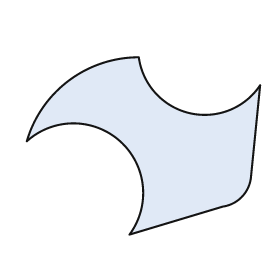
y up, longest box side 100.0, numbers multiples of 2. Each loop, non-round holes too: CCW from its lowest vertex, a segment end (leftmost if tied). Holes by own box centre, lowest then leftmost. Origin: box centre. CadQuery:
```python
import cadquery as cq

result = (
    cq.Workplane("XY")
    .moveTo(-6.0, -38.0)
    .lineTo(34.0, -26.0)
    .threePointArc((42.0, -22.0), (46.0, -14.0))
    .lineTo(50.0, 26.0)
    .threePointArc((20.0, 14.0), (-2.0, 38.0))
    .threePointArc((-32.0, 28.0), (-50.0, 2.0))
    .threePointArc((-10.0, 2.0), (-6.0, -38.0))
    .close()
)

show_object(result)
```